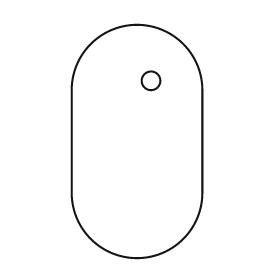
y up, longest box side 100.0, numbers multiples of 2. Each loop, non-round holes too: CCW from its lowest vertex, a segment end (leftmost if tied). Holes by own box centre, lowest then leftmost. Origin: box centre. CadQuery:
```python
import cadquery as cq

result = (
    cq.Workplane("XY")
    .moveTo(-28.0, -22.0)
    .threePointArc((0.0, -50.0), (28.0, -22.0))
    .lineTo(28.0, 22.0)
    .threePointArc((0.0, 50.0), (-28.0, 22.0))
    .close()
    .moveTo(6.0, 26.0)
    .circle(4.0)
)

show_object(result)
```